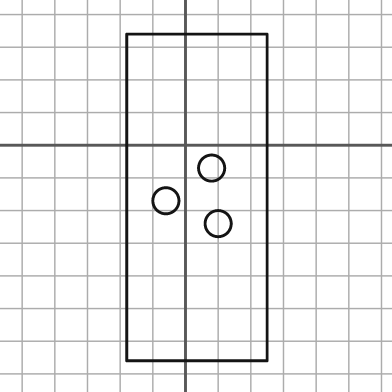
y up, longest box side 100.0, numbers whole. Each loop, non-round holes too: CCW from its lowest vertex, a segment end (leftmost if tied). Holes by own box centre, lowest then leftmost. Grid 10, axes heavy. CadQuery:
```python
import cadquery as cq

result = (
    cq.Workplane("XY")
    .moveTo(-18.0, -66.0)
    .lineTo(25.0, -66.0)
    .lineTo(25.0, 34.0)
    .lineTo(-18.0, 34.0)
    .close()
    .moveTo(10.0, -24.0)
    .circle(4.0)
    .moveTo(-6.0, -17.0)
    .circle(4.0)
    .moveTo(8.0, -7.0)
    .circle(4.0)
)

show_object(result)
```